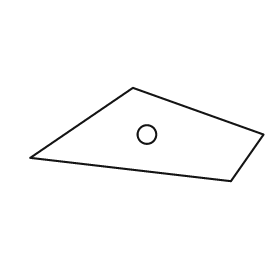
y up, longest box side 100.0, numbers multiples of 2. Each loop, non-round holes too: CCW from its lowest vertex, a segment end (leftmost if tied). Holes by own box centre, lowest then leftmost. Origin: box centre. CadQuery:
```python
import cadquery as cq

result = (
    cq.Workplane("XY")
    .moveTo(36.0, -20.0)
    .lineTo(50.0, 0.0)
    .lineTo(-6.0, 20.0)
    .lineTo(-50.0, -10.0)
    .close()
    .moveTo(0.0, 0.0)
    .circle(4.0)
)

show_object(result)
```